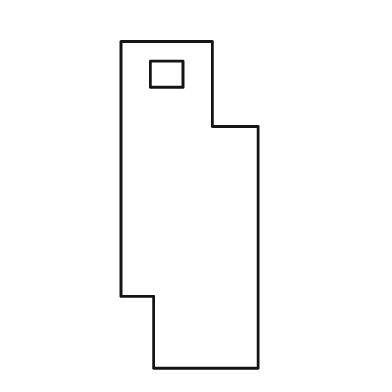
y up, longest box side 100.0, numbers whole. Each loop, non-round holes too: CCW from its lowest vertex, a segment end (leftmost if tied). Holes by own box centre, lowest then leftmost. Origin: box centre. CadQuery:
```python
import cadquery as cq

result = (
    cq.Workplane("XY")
    .moveTo(-11.0, -50.0)
    .lineTo(21.0, -50.0)
    .lineTo(21.0, 24.0)
    .lineTo(7.0, 24.0)
    .lineTo(7.0, 50.0)
    .lineTo(-21.0, 50.0)
    .lineTo(-21.0, -28.0)
    .lineTo(-11.0, -28.0)
    .close()
    .moveTo(-12.0, 36.0)
    .lineTo(-2.0, 36.0)
    .lineTo(-2.0, 44.0)
    .lineTo(-12.0, 44.0)
    .close()
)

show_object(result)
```